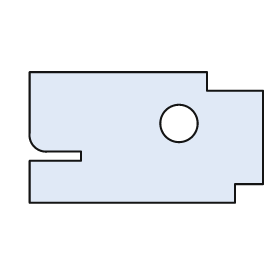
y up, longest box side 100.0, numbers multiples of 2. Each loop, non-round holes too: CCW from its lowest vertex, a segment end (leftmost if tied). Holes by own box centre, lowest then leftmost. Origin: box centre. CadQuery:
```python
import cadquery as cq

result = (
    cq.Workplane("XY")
    .moveTo(-50.0, -28.0)
    .lineTo(38.0, -28.0)
    .lineTo(38.0, -20.0)
    .lineTo(50.0, -20.0)
    .lineTo(50.0, 20.0)
    .lineTo(26.0, 20.0)
    .lineTo(26.0, 28.0)
    .lineTo(-50.0, 28.0)
    .lineTo(-50.0, 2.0)
    .threePointArc((-48.0, -4.0), (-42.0, -6.0))
    .lineTo(-28.0, -6.0)
    .lineTo(-28.0, -10.0)
    .lineTo(-50.0, -10.0)
    .close()
    .moveTo(14.0, 6.0)
    .circle(8.0)
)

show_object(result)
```